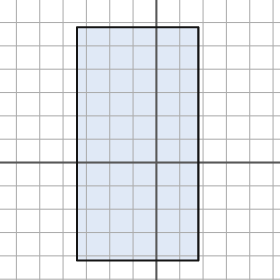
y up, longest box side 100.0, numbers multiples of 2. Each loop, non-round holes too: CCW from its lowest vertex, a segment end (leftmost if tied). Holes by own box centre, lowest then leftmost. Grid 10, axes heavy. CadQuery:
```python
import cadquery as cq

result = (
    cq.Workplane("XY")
    .moveTo(-34.0, -42.0)
    .lineTo(18.0, -42.0)
    .lineTo(18.0, 58.0)
    .lineTo(-34.0, 58.0)
    .close()
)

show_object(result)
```